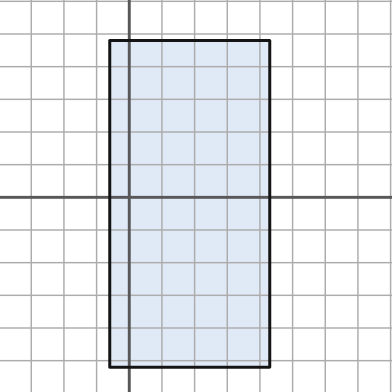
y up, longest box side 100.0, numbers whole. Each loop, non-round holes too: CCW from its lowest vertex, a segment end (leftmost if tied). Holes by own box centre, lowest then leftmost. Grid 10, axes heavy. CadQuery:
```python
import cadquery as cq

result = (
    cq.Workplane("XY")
    .moveTo(-6.0, -52.0)
    .lineTo(43.0, -52.0)
    .lineTo(43.0, 48.0)
    .lineTo(-6.0, 48.0)
    .close()
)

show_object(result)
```